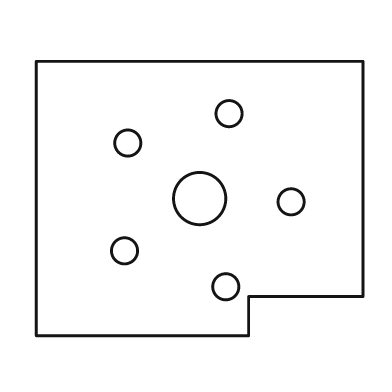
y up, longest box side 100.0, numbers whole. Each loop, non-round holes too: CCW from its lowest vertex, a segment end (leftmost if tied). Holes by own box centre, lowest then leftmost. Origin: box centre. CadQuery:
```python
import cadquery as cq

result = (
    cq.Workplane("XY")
    .moveTo(-50.0, -42.0)
    .lineTo(15.0, -42.0)
    .lineTo(15.0, -30.0)
    .lineTo(50.0, -30.0)
    .lineTo(50.0, 42.0)
    .lineTo(-50.0, 42.0)
    .close()
    .moveTo(8.0, -27.0)
    .circle(4.0)
    .moveTo(-23.0, -16.0)
    .circle(4.0)
    .moveTo(28.0, -1.0)
    .circle(4.0)
    .moveTo(0.0, 0.0)
    .circle(8.0)
    .moveTo(-22.0, 17.0)
    .circle(4.0)
    .moveTo(9.0, 26.0)
    .circle(4.0)
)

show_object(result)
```